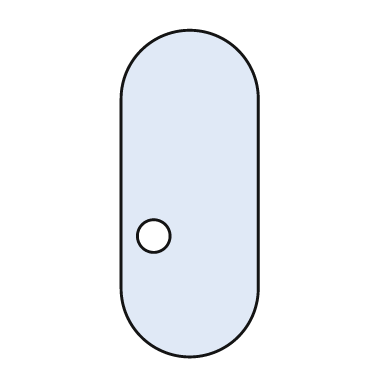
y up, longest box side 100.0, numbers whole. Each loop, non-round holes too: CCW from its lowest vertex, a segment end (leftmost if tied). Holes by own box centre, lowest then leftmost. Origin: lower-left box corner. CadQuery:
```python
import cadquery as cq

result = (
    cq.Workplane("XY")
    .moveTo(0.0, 21.0)
    .threePointArc((21.0, 0.0), (42.0, 21.0))
    .lineTo(42.0, 79.0)
    .threePointArc((21.0, 100.0), (0.0, 79.0))
    .close()
    .moveTo(10.0, 37.0)
    .circle(5.0)
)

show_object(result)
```